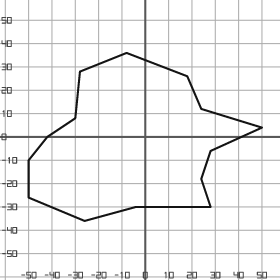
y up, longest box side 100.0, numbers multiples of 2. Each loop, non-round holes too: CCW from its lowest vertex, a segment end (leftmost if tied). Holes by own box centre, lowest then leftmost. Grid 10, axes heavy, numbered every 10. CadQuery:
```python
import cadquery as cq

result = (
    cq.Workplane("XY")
    .moveTo(-26.0, -36.0)
    .lineTo(-4.0, -30.0)
    .lineTo(28.0, -30.0)
    .lineTo(24.0, -18.0)
    .lineTo(28.0, -6.0)
    .lineTo(50.0, 4.0)
    .lineTo(24.0, 12.0)
    .lineTo(18.0, 26.0)
    .lineTo(-8.0, 36.0)
    .lineTo(-28.0, 28.0)
    .lineTo(-30.0, 8.0)
    .lineTo(-42.0, 0.0)
    .lineTo(-50.0, -10.0)
    .lineTo(-50.0, -26.0)
    .close()
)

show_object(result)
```